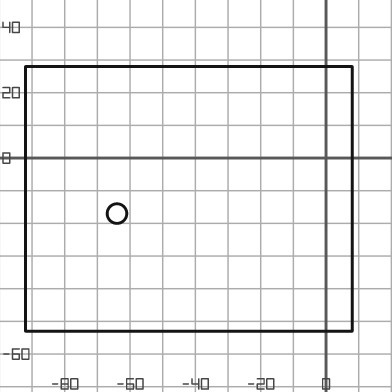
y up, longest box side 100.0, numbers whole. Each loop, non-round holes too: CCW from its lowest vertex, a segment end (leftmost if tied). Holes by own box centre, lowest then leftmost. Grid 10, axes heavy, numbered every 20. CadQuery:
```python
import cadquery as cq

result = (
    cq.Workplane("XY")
    .moveTo(-92.0, -53.0)
    .lineTo(8.0, -53.0)
    .lineTo(8.0, 28.0)
    .lineTo(-92.0, 28.0)
    .close()
    .moveTo(-64.0, -17.0)
    .circle(3.0)
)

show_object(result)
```